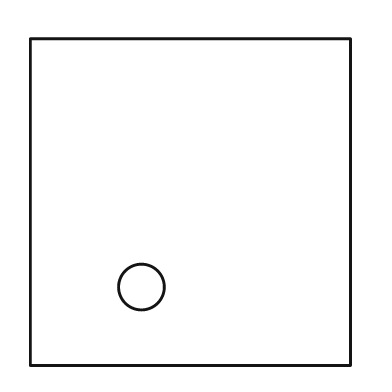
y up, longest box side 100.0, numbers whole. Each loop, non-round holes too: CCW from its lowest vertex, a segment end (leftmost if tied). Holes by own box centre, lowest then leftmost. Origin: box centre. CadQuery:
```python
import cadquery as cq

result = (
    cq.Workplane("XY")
    .moveTo(-49.0, -50.0)
    .lineTo(49.0, -50.0)
    .lineTo(49.0, 50.0)
    .lineTo(-49.0, 50.0)
    .close()
    .moveTo(-15.0, -26.0)
    .circle(7.0)
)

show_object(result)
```